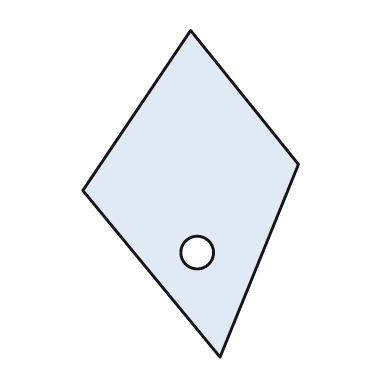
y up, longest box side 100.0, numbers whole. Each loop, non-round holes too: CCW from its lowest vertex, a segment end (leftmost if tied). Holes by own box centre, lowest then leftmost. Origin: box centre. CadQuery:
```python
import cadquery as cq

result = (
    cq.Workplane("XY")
    .moveTo(9.0, -50.0)
    .lineTo(33.0, 9.0)
    .lineTo(0.0, 50.0)
    .lineTo(-33.0, 1.0)
    .close()
    .moveTo(2.0, -18.0)
    .circle(5.0)
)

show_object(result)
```